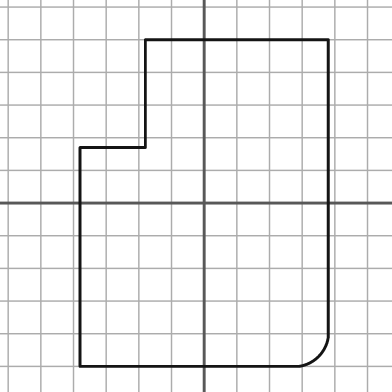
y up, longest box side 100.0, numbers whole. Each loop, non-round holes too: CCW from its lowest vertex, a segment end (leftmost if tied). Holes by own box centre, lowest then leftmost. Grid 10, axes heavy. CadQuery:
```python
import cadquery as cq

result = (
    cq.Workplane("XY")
    .moveTo(-38.0, -50.0)
    .lineTo(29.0, -50.0)
    .threePointArc((35.0, -47.0), (38.0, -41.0))
    .lineTo(38.0, 50.0)
    .lineTo(-18.0, 50.0)
    .lineTo(-18.0, 17.0)
    .lineTo(-38.0, 17.0)
    .close()
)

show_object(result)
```